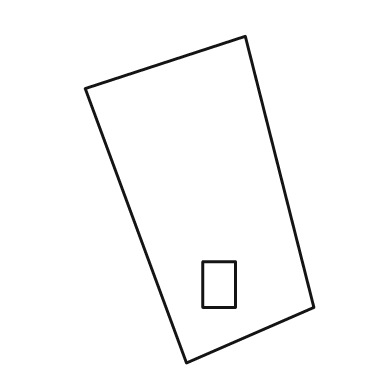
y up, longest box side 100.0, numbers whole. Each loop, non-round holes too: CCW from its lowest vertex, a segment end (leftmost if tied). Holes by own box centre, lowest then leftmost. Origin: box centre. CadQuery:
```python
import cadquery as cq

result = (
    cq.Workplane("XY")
    .moveTo(-4.0, -50.0)
    .lineTo(35.0, -33.0)
    .lineTo(14.0, 50.0)
    .lineTo(-35.0, 34.0)
    .close()
    .moveTo(1.0, -33.0)
    .lineTo(11.0, -33.0)
    .lineTo(11.0, -19.0)
    .lineTo(1.0, -19.0)
    .close()
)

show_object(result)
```